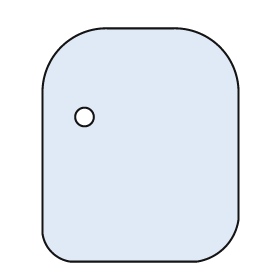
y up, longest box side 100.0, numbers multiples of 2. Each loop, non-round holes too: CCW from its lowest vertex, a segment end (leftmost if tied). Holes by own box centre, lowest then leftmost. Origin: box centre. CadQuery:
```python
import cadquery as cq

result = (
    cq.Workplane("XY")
    .moveTo(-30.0, -50.0)
    .lineTo(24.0, -50.0)
    .threePointArc((36.0, -44.0), (42.0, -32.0))
    .lineTo(42.0, 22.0)
    .threePointArc((34.0, 42.0), (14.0, 50.0))
    .lineTo(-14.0, 50.0)
    .threePointArc((-34.0, 42.0), (-42.0, 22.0))
    .lineTo(-42.0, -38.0)
    .threePointArc((-38.0, -46.0), (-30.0, -50.0))
    .close()
    .moveTo(-24.0, 12.0)
    .circle(4.0)
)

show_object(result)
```